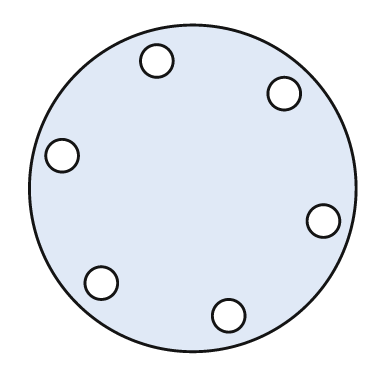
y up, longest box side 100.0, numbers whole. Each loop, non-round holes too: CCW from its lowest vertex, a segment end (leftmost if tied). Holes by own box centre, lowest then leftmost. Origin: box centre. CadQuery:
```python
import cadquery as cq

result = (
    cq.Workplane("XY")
    .moveTo(0.0, 0.0)
    .circle(50.0)
    .moveTo(11.0, -39.0)
    .circle(5.0)
    .moveTo(-28.0, -29.0)
    .circle(5.0)
    .moveTo(40.0, -10.0)
    .circle(5.0)
    .moveTo(-40.0, 10.0)
    .circle(5.0)
    .moveTo(28.0, 29.0)
    .circle(5.0)
    .moveTo(-11.0, 39.0)
    .circle(5.0)
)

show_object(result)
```